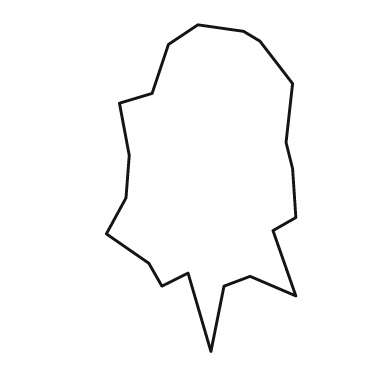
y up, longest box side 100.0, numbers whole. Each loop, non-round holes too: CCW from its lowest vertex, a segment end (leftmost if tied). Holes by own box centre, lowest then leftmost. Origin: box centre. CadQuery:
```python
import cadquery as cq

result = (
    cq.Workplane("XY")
    .moveTo(3.0, -50.0)
    .lineTo(7.0, -30.0)
    .lineTo(15.0, -27.0)
    .lineTo(29.0, -33.0)
    .lineTo(22.0, -13.0)
    .lineTo(29.0, -9.0)
    .lineTo(28.0, 6.0)
    .lineTo(26.0, 14.0)
    .lineTo(28.0, 32.0)
    .lineTo(18.0, 45.0)
    .lineTo(13.0, 48.0)
    .lineTo(-1.0, 50.0)
    .lineTo(-10.0, 44.0)
    .lineTo(-15.0, 29.0)
    .lineTo(-25.0, 26.0)
    .lineTo(-22.0, 10.0)
    .lineTo(-23.0, -3.0)
    .lineTo(-29.0, -14.0)
    .lineTo(-16.0, -23.0)
    .lineTo(-12.0, -30.0)
    .lineTo(-4.0, -26.0)
    .close()
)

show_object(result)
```